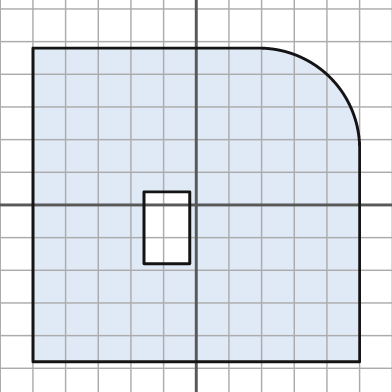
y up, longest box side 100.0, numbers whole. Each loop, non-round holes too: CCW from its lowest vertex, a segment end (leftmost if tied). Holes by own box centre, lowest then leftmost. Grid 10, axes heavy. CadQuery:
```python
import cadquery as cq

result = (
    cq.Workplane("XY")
    .moveTo(-50.0, -48.0)
    .lineTo(50.0, -48.0)
    .lineTo(50.0, 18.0)
    .threePointArc((41.0, 39.0), (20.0, 48.0))
    .lineTo(-50.0, 48.0)
    .close()
    .moveTo(-16.0, -18.0)
    .lineTo(-2.0, -18.0)
    .lineTo(-2.0, 4.0)
    .lineTo(-16.0, 4.0)
    .close()
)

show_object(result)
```